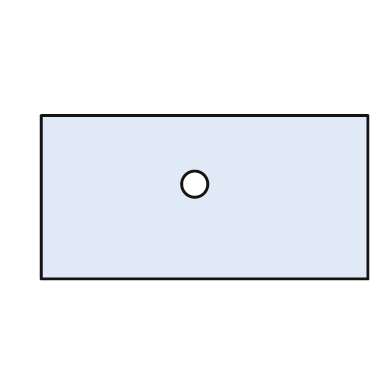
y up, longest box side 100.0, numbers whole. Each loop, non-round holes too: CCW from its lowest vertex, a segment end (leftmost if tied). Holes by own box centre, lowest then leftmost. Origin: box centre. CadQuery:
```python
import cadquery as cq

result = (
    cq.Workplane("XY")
    .moveTo(-50.0, -25.0)
    .lineTo(50.0, -25.0)
    .lineTo(50.0, 25.0)
    .lineTo(-50.0, 25.0)
    .close()
    .moveTo(-3.0, 4.0)
    .circle(4.0)
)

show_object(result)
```